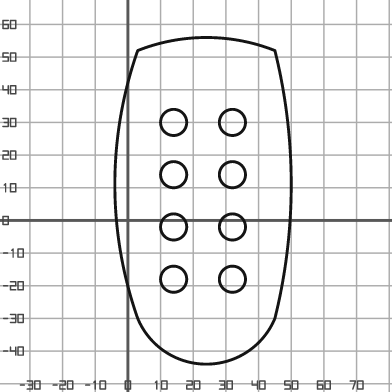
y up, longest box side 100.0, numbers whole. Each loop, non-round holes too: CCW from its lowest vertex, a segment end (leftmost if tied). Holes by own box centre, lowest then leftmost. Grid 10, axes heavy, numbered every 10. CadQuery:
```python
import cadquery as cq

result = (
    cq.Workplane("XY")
    .moveTo(3.0, -30.0)
    .threePointArc((24.0, -44.0), (45.0, -30.0))
    .threePointArc((50.0, 11.0), (45.0, 52.0))
    .threePointArc((24.0, 56.0), (3.0, 52.0))
    .threePointArc((-4.0, 11.0), (3.0, -30.0))
    .close()
    .moveTo(14.0, -18.0)
    .circle(4.0)
    .moveTo(32.0, -18.0)
    .circle(4.0)
    .moveTo(14.0, -2.0)
    .circle(4.0)
    .moveTo(32.0, -2.0)
    .circle(4.0)
    .moveTo(14.0, 14.0)
    .circle(4.0)
    .moveTo(32.0, 14.0)
    .circle(4.0)
    .moveTo(14.0, 30.0)
    .circle(4.0)
    .moveTo(32.0, 30.0)
    .circle(4.0)
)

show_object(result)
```